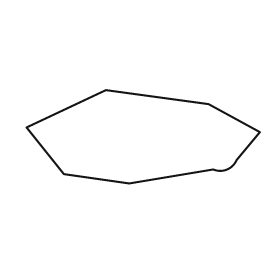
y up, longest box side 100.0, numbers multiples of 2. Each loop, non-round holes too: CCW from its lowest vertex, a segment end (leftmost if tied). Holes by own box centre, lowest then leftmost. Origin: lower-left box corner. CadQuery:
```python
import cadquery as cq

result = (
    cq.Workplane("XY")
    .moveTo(44.0, 0.0)
    .lineTo(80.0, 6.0)
    .threePointArc((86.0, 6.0), (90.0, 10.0))
    .lineTo(100.0, 22.0)
    .lineTo(78.0, 34.0)
    .lineTo(34.0, 40.0)
    .lineTo(0.0, 24.0)
    .lineTo(16.0, 4.0)
    .close()
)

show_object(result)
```